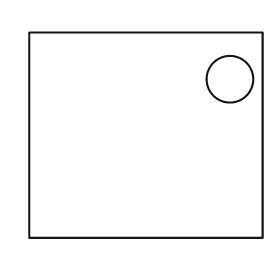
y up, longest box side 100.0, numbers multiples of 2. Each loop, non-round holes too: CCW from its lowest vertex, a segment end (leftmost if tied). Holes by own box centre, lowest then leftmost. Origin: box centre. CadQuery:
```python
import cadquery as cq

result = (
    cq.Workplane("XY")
    .moveTo(-50.0, -44.0)
    .lineTo(50.0, -44.0)
    .lineTo(50.0, 44.0)
    .lineTo(-50.0, 44.0)
    .close()
    .moveTo(36.0, 24.0)
    .circle(10.0)
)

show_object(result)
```